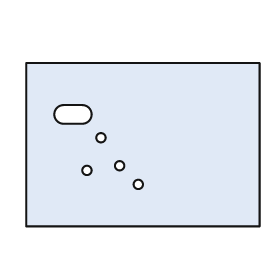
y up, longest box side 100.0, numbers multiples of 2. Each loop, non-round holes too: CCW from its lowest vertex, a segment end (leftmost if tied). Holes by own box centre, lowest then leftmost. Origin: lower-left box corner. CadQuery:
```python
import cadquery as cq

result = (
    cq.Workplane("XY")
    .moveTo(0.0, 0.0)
    .lineTo(100.0, 0.0)
    .lineTo(100.0, 70.0)
    .lineTo(0.0, 70.0)
    .close()
    .moveTo(48.0, 18.0)
    .circle(2.0)
    .moveTo(26.0, 24.0)
    .circle(2.0)
    .moveTo(40.0, 26.0)
    .circle(2.0)
    .moveTo(32.0, 38.0)
    .circle(2.0)
    .moveTo(16.0, 44.0)
    .lineTo(24.0, 44.0)
    .threePointArc((28.0, 48.0), (24.0, 52.0))
    .lineTo(16.0, 52.0)
    .threePointArc((12.0, 48.0), (16.0, 44.0))
    .close()
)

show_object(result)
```